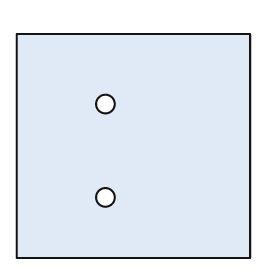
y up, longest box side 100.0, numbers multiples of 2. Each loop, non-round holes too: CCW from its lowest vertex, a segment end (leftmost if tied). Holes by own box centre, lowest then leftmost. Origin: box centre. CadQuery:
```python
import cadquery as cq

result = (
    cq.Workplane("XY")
    .moveTo(-50.0, -48.0)
    .lineTo(50.0, -48.0)
    .lineTo(50.0, 48.0)
    .lineTo(-50.0, 48.0)
    .close()
    .moveTo(-12.0, -22.0)
    .circle(4.0)
    .moveTo(-12.0, 18.0)
    .circle(4.0)
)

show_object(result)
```